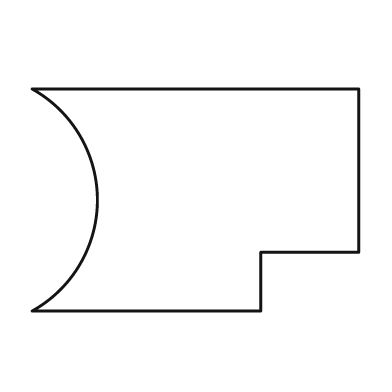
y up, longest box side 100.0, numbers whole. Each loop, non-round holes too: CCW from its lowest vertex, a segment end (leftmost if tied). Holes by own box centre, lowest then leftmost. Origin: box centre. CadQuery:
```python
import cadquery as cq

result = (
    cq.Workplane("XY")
    .moveTo(-50.0, -34.0)
    .lineTo(20.0, -34.0)
    .lineTo(20.0, -16.0)
    .lineTo(50.0, -16.0)
    .lineTo(50.0, 34.0)
    .lineTo(-50.0, 34.0)
    .threePointArc((-30.0, 0.0), (-50.0, -34.0))
    .close()
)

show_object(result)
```